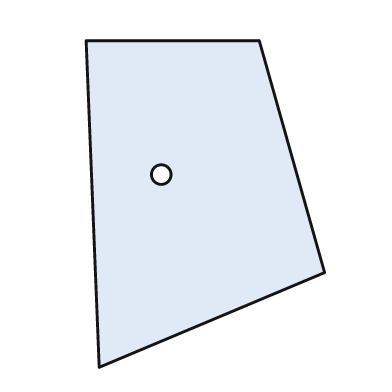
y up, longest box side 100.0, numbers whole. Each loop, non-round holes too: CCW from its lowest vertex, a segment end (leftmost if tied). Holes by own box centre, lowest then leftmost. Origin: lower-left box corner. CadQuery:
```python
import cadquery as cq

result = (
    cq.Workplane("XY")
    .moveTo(4.0, 0.0)
    .lineTo(73.0, 29.0)
    .lineTo(53.0, 100.0)
    .lineTo(0.0, 100.0)
    .close()
    .moveTo(23.0, 59.0)
    .circle(3.0)
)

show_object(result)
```